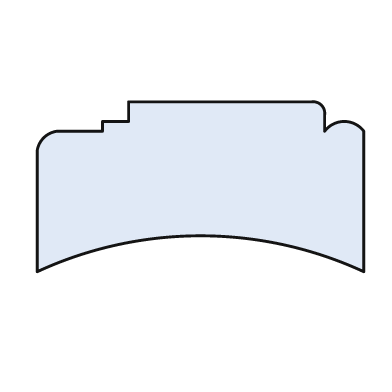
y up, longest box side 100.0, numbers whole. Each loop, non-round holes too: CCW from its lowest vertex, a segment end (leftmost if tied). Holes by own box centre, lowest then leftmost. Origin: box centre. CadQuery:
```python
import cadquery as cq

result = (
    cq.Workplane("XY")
    .moveTo(-50.0, -26.0)
    .threePointArc((0.0, -15.0), (50.0, -26.0))
    .lineTo(50.0, 17.0)
    .threePointArc((44.0, 20.0), (38.0, 17.0))
    .lineTo(38.0, 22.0)
    .threePointArc((37.0, 25.0), (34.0, 26.0))
    .lineTo(-22.0, 26.0)
    .lineTo(-22.0, 20.0)
    .lineTo(-30.0, 20.0)
    .lineTo(-30.0, 17.0)
    .lineTo(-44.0, 17.0)
    .threePointArc((-48.0, 15.0), (-50.0, 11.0))
    .close()
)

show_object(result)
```